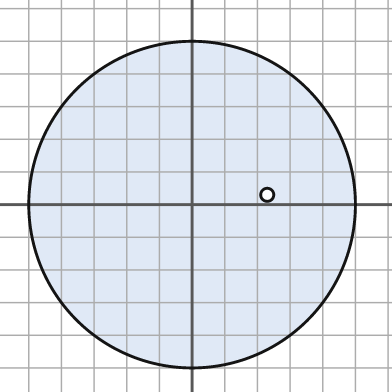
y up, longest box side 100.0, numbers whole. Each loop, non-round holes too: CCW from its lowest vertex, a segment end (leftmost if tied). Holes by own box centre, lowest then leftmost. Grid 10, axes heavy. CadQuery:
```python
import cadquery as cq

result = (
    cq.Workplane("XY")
    .moveTo(0.0, 0.0)
    .circle(50.0)
    .moveTo(23.0, 3.0)
    .circle(2.0)
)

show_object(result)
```